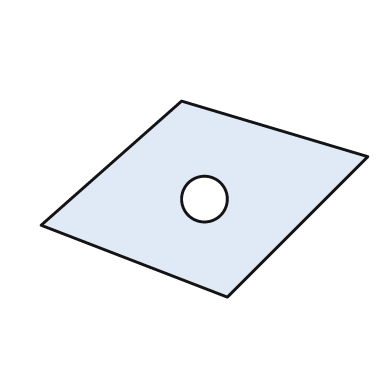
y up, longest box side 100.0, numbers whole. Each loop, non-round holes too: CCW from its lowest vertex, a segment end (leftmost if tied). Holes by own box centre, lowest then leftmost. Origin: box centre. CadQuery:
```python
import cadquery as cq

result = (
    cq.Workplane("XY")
    .moveTo(7.0, -30.0)
    .lineTo(50.0, 13.0)
    .lineTo(-7.0, 30.0)
    .lineTo(-50.0, -8.0)
    .close()
    .moveTo(0.0, 0.0)
    .circle(7.0)
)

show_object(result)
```